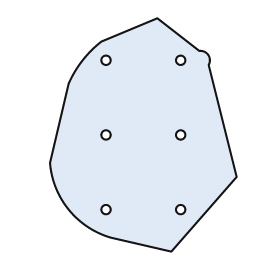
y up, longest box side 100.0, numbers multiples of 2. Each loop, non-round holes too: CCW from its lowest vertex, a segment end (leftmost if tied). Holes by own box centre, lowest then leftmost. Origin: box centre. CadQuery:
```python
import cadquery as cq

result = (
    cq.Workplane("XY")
    .moveTo(12.0, -50.0)
    .lineTo(40.0, -18.0)
    .lineTo(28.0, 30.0)
    .threePointArc((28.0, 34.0), (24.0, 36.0))
    .lineTo(6.0, 50.0)
    .lineTo(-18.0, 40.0)
    .threePointArc((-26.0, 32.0), (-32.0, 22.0))
    .lineTo(-40.0, -12.0)
    .threePointArc((-32.0, -32.0), (-14.0, -44.0))
    .close()
    .moveTo(-16.0, -32.0)
    .circle(2.0)
    .moveTo(16.0, -32.0)
    .circle(2.0)
    .moveTo(-16.0, 0.0)
    .circle(2.0)
    .moveTo(16.0, 0.0)
    .circle(2.0)
    .moveTo(-16.0, 32.0)
    .circle(2.0)
    .moveTo(16.0, 32.0)
    .circle(2.0)
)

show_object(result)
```